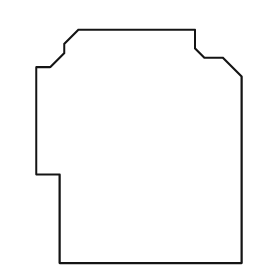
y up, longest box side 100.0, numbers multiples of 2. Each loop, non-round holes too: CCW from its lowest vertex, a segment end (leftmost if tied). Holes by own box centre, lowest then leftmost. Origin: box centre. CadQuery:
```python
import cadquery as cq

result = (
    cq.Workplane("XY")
    .moveTo(-34.0, -50.0)
    .lineTo(44.0, -50.0)
    .lineTo(44.0, 30.0)
    .lineTo(36.0, 38.0)
    .lineTo(28.0, 38.0)
    .lineTo(24.0, 42.0)
    .lineTo(24.0, 50.0)
    .lineTo(-26.0, 50.0)
    .lineTo(-32.0, 44.0)
    .lineTo(-32.0, 40.0)
    .lineTo(-38.0, 34.0)
    .lineTo(-44.0, 34.0)
    .lineTo(-44.0, -12.0)
    .lineTo(-34.0, -12.0)
    .close()
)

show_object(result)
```